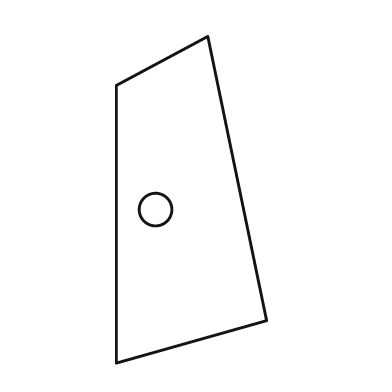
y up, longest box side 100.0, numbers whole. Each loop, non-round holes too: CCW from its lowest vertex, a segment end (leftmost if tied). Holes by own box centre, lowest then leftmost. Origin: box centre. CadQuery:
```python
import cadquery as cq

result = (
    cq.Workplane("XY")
    .moveTo(-23.0, -50.0)
    .lineTo(23.0, -37.0)
    .lineTo(5.0, 50.0)
    .lineTo(-23.0, 35.0)
    .close()
    .moveTo(-11.0, -3.0)
    .circle(5.0)
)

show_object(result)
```